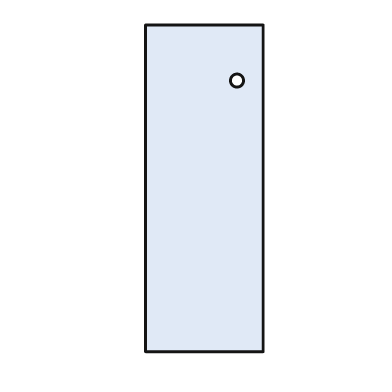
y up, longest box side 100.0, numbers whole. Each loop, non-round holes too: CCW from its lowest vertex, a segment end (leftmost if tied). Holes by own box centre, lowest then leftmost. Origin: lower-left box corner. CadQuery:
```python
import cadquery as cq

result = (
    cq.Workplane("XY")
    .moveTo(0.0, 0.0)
    .lineTo(36.0, 0.0)
    .lineTo(36.0, 100.0)
    .lineTo(0.0, 100.0)
    .close()
    .moveTo(28.0, 83.0)
    .circle(2.0)
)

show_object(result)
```